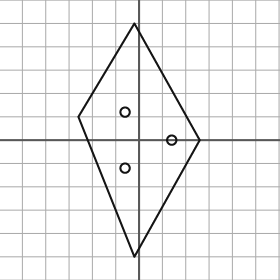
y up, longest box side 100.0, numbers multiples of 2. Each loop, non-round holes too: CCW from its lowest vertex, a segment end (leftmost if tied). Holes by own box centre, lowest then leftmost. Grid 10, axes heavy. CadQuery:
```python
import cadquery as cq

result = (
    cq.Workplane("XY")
    .moveTo(-2.0, -50.0)
    .lineTo(26.0, 0.0)
    .lineTo(-2.0, 50.0)
    .lineTo(-26.0, 10.0)
    .close()
    .moveTo(-6.0, -12.0)
    .circle(2.0)
    .moveTo(14.0, 0.0)
    .circle(2.0)
    .moveTo(-6.0, 12.0)
    .circle(2.0)
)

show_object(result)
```